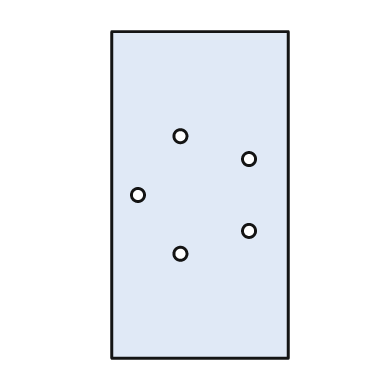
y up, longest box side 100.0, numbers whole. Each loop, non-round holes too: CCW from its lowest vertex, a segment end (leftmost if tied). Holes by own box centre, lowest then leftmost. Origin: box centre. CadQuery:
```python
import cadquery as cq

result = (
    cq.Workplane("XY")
    .moveTo(-27.0, -50.0)
    .lineTo(27.0, -50.0)
    .lineTo(27.0, 50.0)
    .lineTo(-27.0, 50.0)
    .close()
    .moveTo(-6.0, -18.0)
    .circle(2.0)
    .moveTo(15.0, -11.0)
    .circle(2.0)
    .moveTo(-19.0, 0.0)
    .circle(2.0)
    .moveTo(15.0, 11.0)
    .circle(2.0)
    .moveTo(-6.0, 18.0)
    .circle(2.0)
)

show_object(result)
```